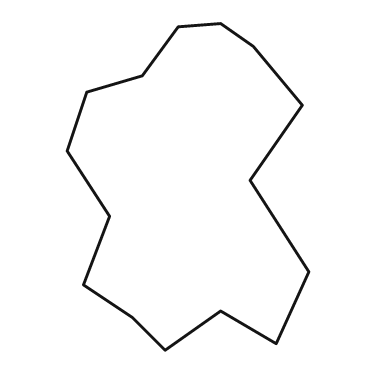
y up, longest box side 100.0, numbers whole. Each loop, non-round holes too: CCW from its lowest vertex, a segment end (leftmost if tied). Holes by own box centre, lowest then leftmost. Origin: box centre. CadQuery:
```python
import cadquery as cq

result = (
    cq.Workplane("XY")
    .moveTo(-7.0, -50.0)
    .lineTo(10.0, -38.0)
    .lineTo(27.0, -48.0)
    .lineTo(37.0, -26.0)
    .lineTo(19.0, 2.0)
    .lineTo(35.0, 25.0)
    .lineTo(20.0, 43.0)
    .lineTo(10.0, 50.0)
    .lineTo(-3.0, 49.0)
    .lineTo(-14.0, 34.0)
    .lineTo(-31.0, 29.0)
    .lineTo(-37.0, 11.0)
    .lineTo(-24.0, -9.0)
    .lineTo(-32.0, -30.0)
    .lineTo(-17.0, -40.0)
    .close()
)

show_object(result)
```